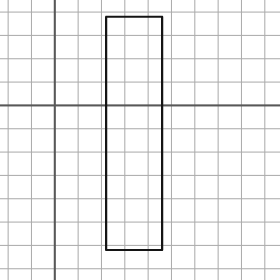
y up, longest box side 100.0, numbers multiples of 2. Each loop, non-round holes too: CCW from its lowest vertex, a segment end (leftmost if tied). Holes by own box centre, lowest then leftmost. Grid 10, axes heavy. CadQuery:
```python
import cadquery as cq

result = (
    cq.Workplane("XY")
    .moveTo(22.0, -62.0)
    .lineTo(46.0, -62.0)
    .lineTo(46.0, 38.0)
    .lineTo(22.0, 38.0)
    .close()
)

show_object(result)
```